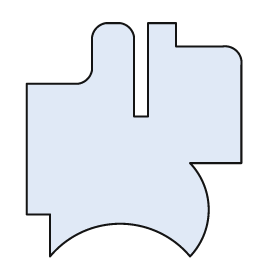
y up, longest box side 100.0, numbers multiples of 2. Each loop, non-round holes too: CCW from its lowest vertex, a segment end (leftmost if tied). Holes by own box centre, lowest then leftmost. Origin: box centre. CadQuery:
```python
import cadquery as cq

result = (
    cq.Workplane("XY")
    .moveTo(-36.0, -50.0)
    .threePointArc((-6.0, -36.0), (24.0, -50.0))
    .threePointArc((32.0, -30.0), (24.0, -10.0))
    .lineTo(46.0, -10.0)
    .lineTo(46.0, 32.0)
    .threePointArc((44.0, 38.0), (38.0, 40.0))
    .lineTo(18.0, 40.0)
    .lineTo(18.0, 50.0)
    .lineTo(6.0, 50.0)
    .lineTo(6.0, 10.0)
    .lineTo(0.0, 10.0)
    .lineTo(0.0, 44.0)
    .threePointArc((-2.0, 48.0), (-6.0, 50.0))
    .lineTo(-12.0, 50.0)
    .threePointArc((-16.0, 48.0), (-18.0, 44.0))
    .lineTo(-18.0, 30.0)
    .threePointArc((-20.0, 26.0), (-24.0, 24.0))
    .lineTo(-46.0, 24.0)
    .lineTo(-46.0, -32.0)
    .lineTo(-36.0, -32.0)
    .close()
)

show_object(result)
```